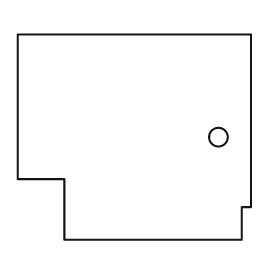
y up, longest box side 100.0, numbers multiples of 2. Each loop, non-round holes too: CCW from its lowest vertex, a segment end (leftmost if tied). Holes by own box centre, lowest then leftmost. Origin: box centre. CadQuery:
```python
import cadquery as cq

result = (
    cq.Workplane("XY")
    .moveTo(-30.0, -44.0)
    .lineTo(46.0, -44.0)
    .lineTo(46.0, -30.0)
    .lineTo(50.0, -30.0)
    .lineTo(50.0, 44.0)
    .lineTo(-50.0, 44.0)
    .lineTo(-50.0, -18.0)
    .lineTo(-30.0, -18.0)
    .close()
    .moveTo(36.0, 0.0)
    .circle(4.0)
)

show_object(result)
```